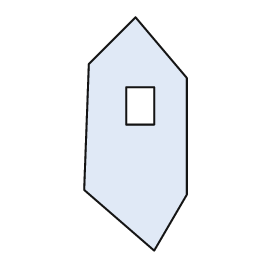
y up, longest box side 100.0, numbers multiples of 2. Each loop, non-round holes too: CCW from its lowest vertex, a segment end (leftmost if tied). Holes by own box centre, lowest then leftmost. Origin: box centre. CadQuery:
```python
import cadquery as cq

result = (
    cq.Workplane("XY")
    .moveTo(8.0, -50.0)
    .lineTo(22.0, -26.0)
    .lineTo(22.0, 24.0)
    .lineTo(0.0, 50.0)
    .lineTo(-20.0, 30.0)
    .lineTo(-22.0, -24.0)
    .close()
    .moveTo(-4.0, 4.0)
    .lineTo(8.0, 4.0)
    .lineTo(8.0, 20.0)
    .lineTo(-4.0, 20.0)
    .close()
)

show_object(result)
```